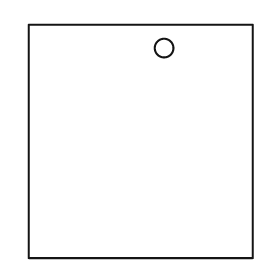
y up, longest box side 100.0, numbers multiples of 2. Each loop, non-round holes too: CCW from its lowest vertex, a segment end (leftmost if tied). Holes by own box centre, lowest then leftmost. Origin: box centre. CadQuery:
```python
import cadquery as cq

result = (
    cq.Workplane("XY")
    .moveTo(-48.0, -50.0)
    .lineTo(48.0, -50.0)
    .lineTo(48.0, 50.0)
    .lineTo(-48.0, 50.0)
    .close()
    .moveTo(10.0, 40.0)
    .circle(4.0)
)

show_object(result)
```